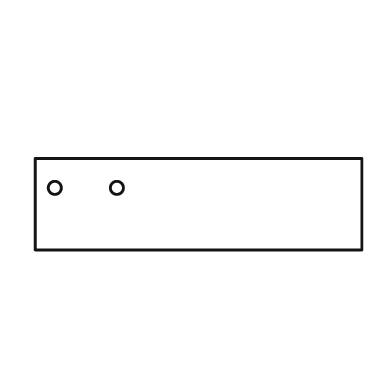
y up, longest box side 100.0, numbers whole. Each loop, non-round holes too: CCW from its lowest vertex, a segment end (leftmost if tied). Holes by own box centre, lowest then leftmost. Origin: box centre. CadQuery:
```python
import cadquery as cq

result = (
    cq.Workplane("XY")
    .moveTo(-50.0, -14.0)
    .lineTo(50.0, -14.0)
    .lineTo(50.0, 14.0)
    .lineTo(-50.0, 14.0)
    .close()
    .moveTo(-44.0, 5.0)
    .circle(2.0)
    .moveTo(-25.0, 5.0)
    .circle(2.0)
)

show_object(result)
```